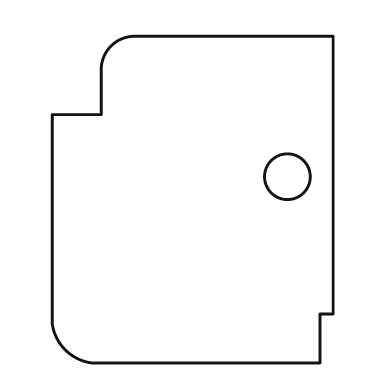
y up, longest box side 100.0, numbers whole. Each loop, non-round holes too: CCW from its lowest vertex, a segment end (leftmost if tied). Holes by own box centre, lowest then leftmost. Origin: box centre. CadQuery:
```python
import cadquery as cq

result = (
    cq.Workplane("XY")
    .moveTo(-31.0, -50.0)
    .lineTo(39.0, -50.0)
    .lineTo(39.0, -35.0)
    .lineTo(43.0, -35.0)
    .lineTo(43.0, 50.0)
    .lineTo(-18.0, 50.0)
    .threePointArc((-25.0, 47.0), (-28.0, 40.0))
    .lineTo(-28.0, 26.0)
    .lineTo(-43.0, 26.0)
    .lineTo(-43.0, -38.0)
    .threePointArc((-39.0, -46.0), (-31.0, -50.0))
    .close()
    .moveTo(29.0, 7.0)
    .circle(7.0)
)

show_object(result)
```